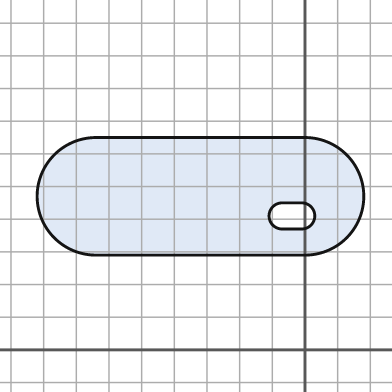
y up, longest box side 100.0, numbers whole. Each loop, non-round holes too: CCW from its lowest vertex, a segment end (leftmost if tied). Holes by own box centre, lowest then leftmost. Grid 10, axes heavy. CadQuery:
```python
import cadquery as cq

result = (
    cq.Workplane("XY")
    .moveTo(-64.0, 29.0)
    .lineTo(0.0, 29.0)
    .threePointArc((18.0, 47.0), (0.0, 65.0))
    .lineTo(-64.0, 65.0)
    .threePointArc((-82.0, 47.0), (-64.0, 29.0))
    .close()
    .moveTo(-7.0, 37.0)
    .lineTo(-1.0, 37.0)
    .threePointArc((3.0, 41.0), (-1.0, 45.0))
    .lineTo(-7.0, 45.0)
    .threePointArc((-11.0, 41.0), (-7.0, 37.0))
    .close()
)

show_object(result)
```